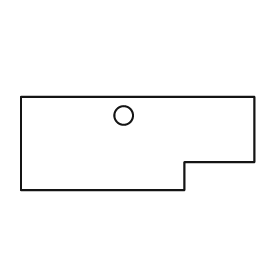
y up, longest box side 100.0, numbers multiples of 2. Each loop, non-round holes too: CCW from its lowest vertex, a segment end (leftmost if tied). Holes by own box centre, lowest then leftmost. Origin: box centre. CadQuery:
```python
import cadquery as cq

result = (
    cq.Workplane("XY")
    .moveTo(-50.0, -20.0)
    .lineTo(20.0, -20.0)
    .lineTo(20.0, -8.0)
    .lineTo(50.0, -8.0)
    .lineTo(50.0, 20.0)
    .lineTo(-50.0, 20.0)
    .close()
    .moveTo(-6.0, 12.0)
    .circle(4.0)
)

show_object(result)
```